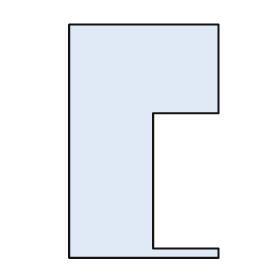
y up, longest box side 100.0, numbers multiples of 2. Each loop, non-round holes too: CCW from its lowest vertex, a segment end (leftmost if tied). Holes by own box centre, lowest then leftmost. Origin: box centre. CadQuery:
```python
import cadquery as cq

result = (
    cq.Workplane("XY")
    .moveTo(-32.0, -50.0)
    .lineTo(32.0, -50.0)
    .lineTo(32.0, -46.0)
    .lineTo(4.0, -46.0)
    .lineTo(4.0, 12.0)
    .lineTo(32.0, 12.0)
    .lineTo(32.0, 50.0)
    .lineTo(-32.0, 50.0)
    .close()
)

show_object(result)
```